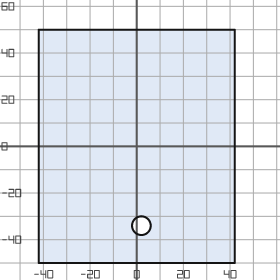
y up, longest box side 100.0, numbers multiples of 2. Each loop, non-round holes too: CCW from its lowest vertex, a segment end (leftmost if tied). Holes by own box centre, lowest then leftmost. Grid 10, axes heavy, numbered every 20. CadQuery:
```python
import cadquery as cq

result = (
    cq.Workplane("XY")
    .moveTo(-42.0, -50.0)
    .lineTo(42.0, -50.0)
    .lineTo(42.0, 50.0)
    .lineTo(-42.0, 50.0)
    .close()
    .moveTo(2.0, -34.0)
    .circle(4.0)
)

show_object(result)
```